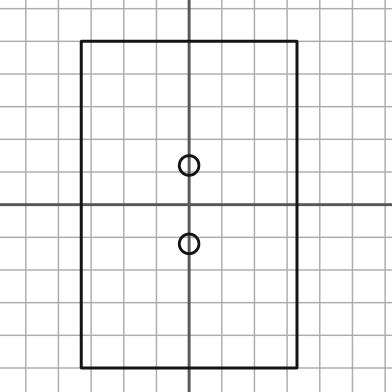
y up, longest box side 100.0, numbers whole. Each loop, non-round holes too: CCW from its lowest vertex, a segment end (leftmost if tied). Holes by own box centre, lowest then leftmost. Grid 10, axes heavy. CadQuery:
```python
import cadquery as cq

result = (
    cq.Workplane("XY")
    .moveTo(-33.0, -50.0)
    .lineTo(33.0, -50.0)
    .lineTo(33.0, 50.0)
    .lineTo(-33.0, 50.0)
    .close()
    .moveTo(0.0, -12.0)
    .circle(3.0)
    .moveTo(0.0, 12.0)
    .circle(3.0)
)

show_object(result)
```